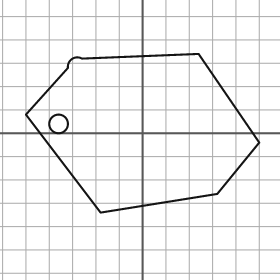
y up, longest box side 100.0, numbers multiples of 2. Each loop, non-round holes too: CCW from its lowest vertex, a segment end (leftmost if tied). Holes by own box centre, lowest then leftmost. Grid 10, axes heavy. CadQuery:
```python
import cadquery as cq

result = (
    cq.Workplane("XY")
    .moveTo(-18.0, -34.0)
    .lineTo(32.0, -26.0)
    .lineTo(50.0, -4.0)
    .lineTo(24.0, 34.0)
    .lineTo(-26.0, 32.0)
    .threePointArc((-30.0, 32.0), (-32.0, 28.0))
    .lineTo(-50.0, 8.0)
    .close()
    .moveTo(-36.0, 4.0)
    .circle(4.0)
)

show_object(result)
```